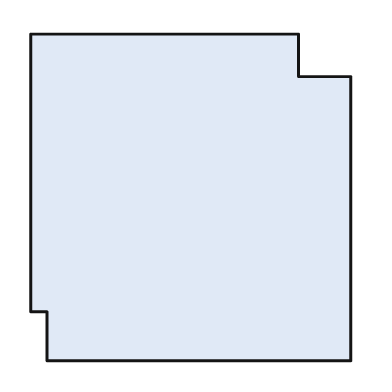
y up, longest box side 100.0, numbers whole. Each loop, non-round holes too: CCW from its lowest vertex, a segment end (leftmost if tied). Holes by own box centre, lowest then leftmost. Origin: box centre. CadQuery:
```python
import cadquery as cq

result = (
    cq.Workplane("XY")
    .moveTo(-44.0, -50.0)
    .lineTo(49.0, -50.0)
    .lineTo(49.0, 37.0)
    .lineTo(33.0, 37.0)
    .lineTo(33.0, 50.0)
    .lineTo(-49.0, 50.0)
    .lineTo(-49.0, -35.0)
    .lineTo(-44.0, -35.0)
    .close()
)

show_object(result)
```